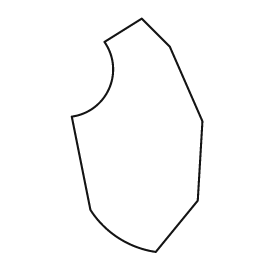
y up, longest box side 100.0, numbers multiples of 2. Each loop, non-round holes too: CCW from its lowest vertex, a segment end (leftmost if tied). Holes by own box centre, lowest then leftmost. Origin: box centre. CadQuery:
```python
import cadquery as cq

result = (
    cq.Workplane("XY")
    .moveTo(8.0, -50.0)
    .lineTo(26.0, -28.0)
    .lineTo(28.0, 6.0)
    .lineTo(14.0, 38.0)
    .lineTo(2.0, 50.0)
    .lineTo(-14.0, 40.0)
    .threePointArc((-12.0, 20.0), (-28.0, 8.0))
    .lineTo(-20.0, -32.0)
    .threePointArc((-8.0, -44.0), (8.0, -50.0))
    .close()
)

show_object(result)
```